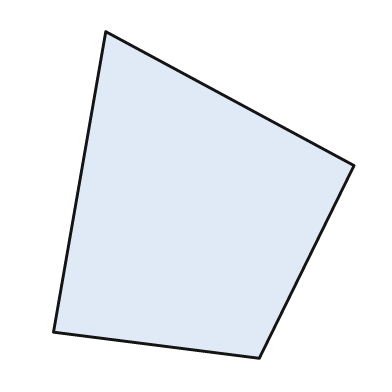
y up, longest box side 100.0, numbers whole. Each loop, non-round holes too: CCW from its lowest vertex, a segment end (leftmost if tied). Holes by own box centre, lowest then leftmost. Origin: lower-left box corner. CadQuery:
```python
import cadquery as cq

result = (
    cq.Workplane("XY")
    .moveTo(63.0, 0.0)
    .lineTo(92.0, 59.0)
    .lineTo(16.0, 100.0)
    .lineTo(0.0, 8.0)
    .close()
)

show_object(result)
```